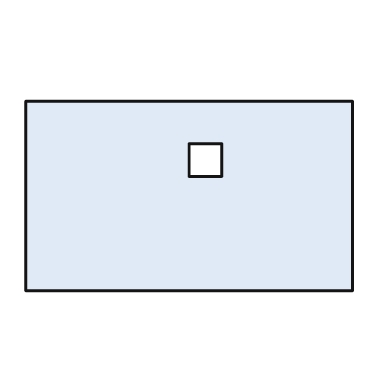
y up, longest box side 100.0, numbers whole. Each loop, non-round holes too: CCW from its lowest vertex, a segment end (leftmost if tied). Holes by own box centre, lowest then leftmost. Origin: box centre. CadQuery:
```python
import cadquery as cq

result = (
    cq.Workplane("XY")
    .moveTo(-50.0, -29.0)
    .lineTo(50.0, -29.0)
    .lineTo(50.0, 29.0)
    .lineTo(-50.0, 29.0)
    .close()
    .moveTo(0.0, 6.0)
    .lineTo(10.0, 6.0)
    .lineTo(10.0, 16.0)
    .lineTo(0.0, 16.0)
    .close()
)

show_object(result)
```